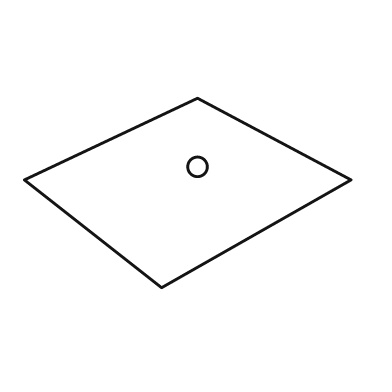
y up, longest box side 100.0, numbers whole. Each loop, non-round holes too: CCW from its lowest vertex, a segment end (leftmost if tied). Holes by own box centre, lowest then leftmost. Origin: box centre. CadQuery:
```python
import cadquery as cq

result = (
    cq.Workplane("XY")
    .moveTo(-8.0, -29.0)
    .lineTo(50.0, 4.0)
    .lineTo(3.0, 29.0)
    .lineTo(-50.0, 4.0)
    .close()
    .moveTo(3.0, 8.0)
    .circle(3.0)
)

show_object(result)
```